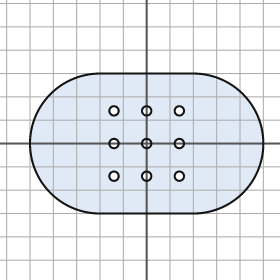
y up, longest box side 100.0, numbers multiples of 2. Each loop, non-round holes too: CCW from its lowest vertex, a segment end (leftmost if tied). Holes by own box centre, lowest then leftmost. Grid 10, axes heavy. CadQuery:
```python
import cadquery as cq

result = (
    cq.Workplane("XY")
    .moveTo(-20.0, -30.0)
    .lineTo(20.0, -30.0)
    .threePointArc((50.0, 0.0), (20.0, 30.0))
    .lineTo(-20.0, 30.0)
    .threePointArc((-50.0, 0.0), (-20.0, -30.0))
    .close()
    .moveTo(-14.0, -14.0)
    .circle(2.0)
    .moveTo(0.0, -14.0)
    .circle(2.0)
    .moveTo(14.0, -14.0)
    .circle(2.0)
    .moveTo(-14.0, 0.0)
    .circle(2.0)
    .moveTo(0.0, 0.0)
    .circle(2.0)
    .moveTo(14.0, 0.0)
    .circle(2.0)
    .moveTo(-14.0, 14.0)
    .circle(2.0)
    .moveTo(0.0, 14.0)
    .circle(2.0)
    .moveTo(14.0, 14.0)
    .circle(2.0)
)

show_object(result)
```